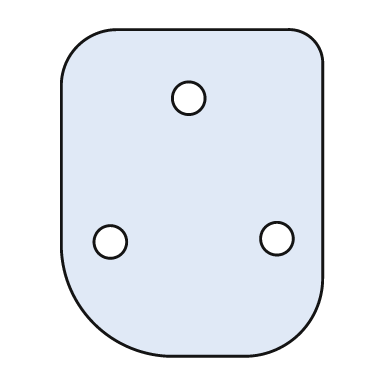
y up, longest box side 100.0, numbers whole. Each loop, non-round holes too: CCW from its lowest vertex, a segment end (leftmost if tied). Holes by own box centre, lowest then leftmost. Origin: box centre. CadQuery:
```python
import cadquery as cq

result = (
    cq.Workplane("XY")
    .moveTo(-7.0, -50.0)
    .lineTo(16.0, -50.0)
    .threePointArc((33.0, -43.0), (40.0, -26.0))
    .lineTo(40.0, 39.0)
    .threePointArc((37.0, 47.0), (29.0, 50.0))
    .lineTo(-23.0, 50.0)
    .threePointArc((-35.0, 45.0), (-40.0, 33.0))
    .lineTo(-40.0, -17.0)
    .threePointArc((-30.0, -40.0), (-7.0, -50.0))
    .close()
    .moveTo(-25.0, -15.0)
    .circle(5.0)
    .moveTo(26.0, -14.0)
    .circle(5.0)
    .moveTo(-1.0, 29.0)
    .circle(5.0)
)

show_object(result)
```